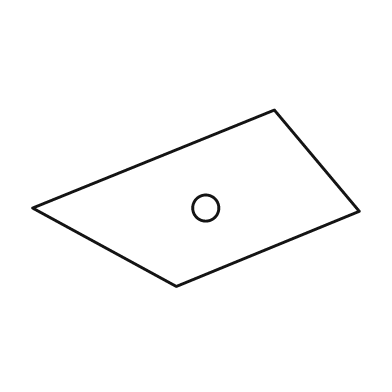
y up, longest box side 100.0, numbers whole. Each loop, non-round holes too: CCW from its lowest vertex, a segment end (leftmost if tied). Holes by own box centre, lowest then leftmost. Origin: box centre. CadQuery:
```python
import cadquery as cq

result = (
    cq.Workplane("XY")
    .moveTo(-6.0, -27.0)
    .lineTo(50.0, -4.0)
    .lineTo(24.0, 27.0)
    .lineTo(-50.0, -3.0)
    .close()
    .moveTo(3.0, -3.0)
    .circle(4.0)
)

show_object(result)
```